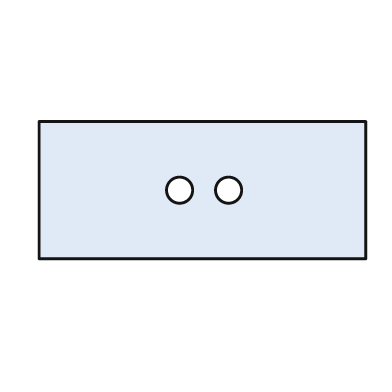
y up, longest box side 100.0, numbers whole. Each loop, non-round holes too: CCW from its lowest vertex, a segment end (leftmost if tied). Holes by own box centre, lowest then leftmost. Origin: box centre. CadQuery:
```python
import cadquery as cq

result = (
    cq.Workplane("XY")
    .moveTo(-50.0, -21.0)
    .lineTo(50.0, -21.0)
    .lineTo(50.0, 21.0)
    .lineTo(-50.0, 21.0)
    .close()
    .moveTo(-7.0, 0.0)
    .circle(4.0)
    .moveTo(8.0, 0.0)
    .circle(4.0)
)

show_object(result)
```